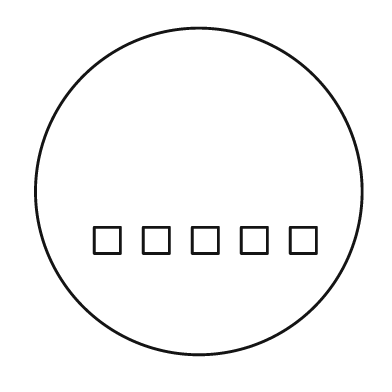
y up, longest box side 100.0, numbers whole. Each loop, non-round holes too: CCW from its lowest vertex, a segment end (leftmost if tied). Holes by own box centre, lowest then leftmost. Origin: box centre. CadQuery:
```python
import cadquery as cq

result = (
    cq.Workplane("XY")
    .moveTo(0.0, 0.0)
    .circle(50.0)
    .moveTo(-32.0, -19.0)
    .lineTo(-24.0, -19.0)
    .lineTo(-24.0, -11.0)
    .lineTo(-32.0, -11.0)
    .close()
    .moveTo(-17.0, -19.0)
    .lineTo(-9.0, -19.0)
    .lineTo(-9.0, -11.0)
    .lineTo(-17.0, -11.0)
    .close()
    .moveTo(-2.0, -19.0)
    .lineTo(6.0, -19.0)
    .lineTo(6.0, -11.0)
    .lineTo(-2.0, -11.0)
    .close()
    .moveTo(13.0, -19.0)
    .lineTo(21.0, -19.0)
    .lineTo(21.0, -11.0)
    .lineTo(13.0, -11.0)
    .close()
    .moveTo(28.0, -19.0)
    .lineTo(36.0, -19.0)
    .lineTo(36.0, -11.0)
    .lineTo(28.0, -11.0)
    .close()
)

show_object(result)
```